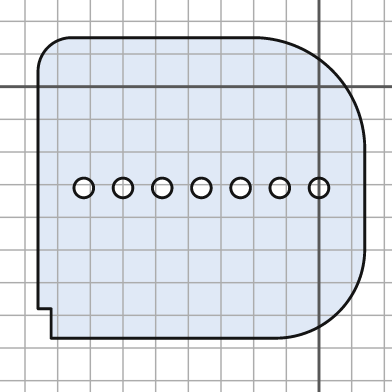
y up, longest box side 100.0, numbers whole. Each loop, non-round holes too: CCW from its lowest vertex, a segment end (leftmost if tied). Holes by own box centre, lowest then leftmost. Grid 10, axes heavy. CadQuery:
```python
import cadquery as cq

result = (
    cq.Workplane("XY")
    .moveTo(-82.0, -77.0)
    .lineTo(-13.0, -77.0)
    .threePointArc((6.0, -69.0), (14.0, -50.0))
    .lineTo(14.0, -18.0)
    .threePointArc((4.0, 5.0), (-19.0, 15.0))
    .lineTo(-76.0, 15.0)
    .threePointArc((-83.0, 12.0), (-86.0, 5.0))
    .lineTo(-86.0, -68.0)
    .lineTo(-82.0, -68.0)
    .close()
    .moveTo(-72.0, -31.0)
    .circle(3.0)
    .moveTo(-60.0, -31.0)
    .circle(3.0)
    .moveTo(-48.0, -31.0)
    .circle(3.0)
    .moveTo(-36.0, -31.0)
    .circle(3.0)
    .moveTo(-24.0, -31.0)
    .circle(3.0)
    .moveTo(-12.0, -31.0)
    .circle(3.0)
    .moveTo(0.0, -31.0)
    .circle(3.0)
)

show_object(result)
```